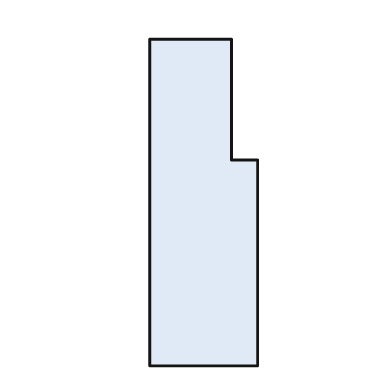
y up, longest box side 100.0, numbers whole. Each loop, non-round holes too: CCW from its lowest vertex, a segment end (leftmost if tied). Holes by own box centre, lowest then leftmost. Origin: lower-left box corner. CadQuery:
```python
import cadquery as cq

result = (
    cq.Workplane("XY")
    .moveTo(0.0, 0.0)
    .lineTo(33.0, 0.0)
    .lineTo(33.0, 63.0)
    .lineTo(25.0, 63.0)
    .lineTo(25.0, 100.0)
    .lineTo(0.0, 100.0)
    .close()
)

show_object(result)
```